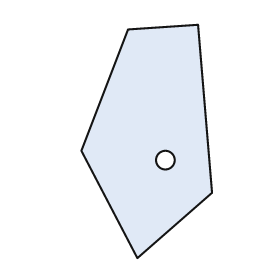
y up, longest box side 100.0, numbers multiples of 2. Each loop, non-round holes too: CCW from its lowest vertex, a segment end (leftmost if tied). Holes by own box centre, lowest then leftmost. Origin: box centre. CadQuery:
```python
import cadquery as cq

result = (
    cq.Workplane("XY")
    .moveTo(-4.0, -50.0)
    .lineTo(28.0, -22.0)
    .lineTo(22.0, 50.0)
    .lineTo(-8.0, 48.0)
    .lineTo(-28.0, -4.0)
    .close()
    .moveTo(8.0, -8.0)
    .circle(4.0)
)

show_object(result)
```